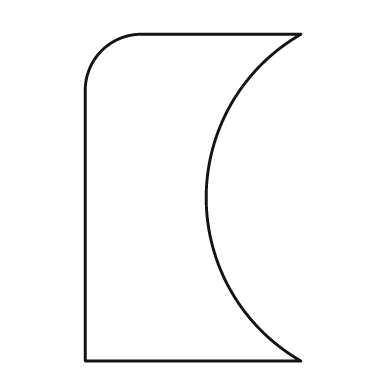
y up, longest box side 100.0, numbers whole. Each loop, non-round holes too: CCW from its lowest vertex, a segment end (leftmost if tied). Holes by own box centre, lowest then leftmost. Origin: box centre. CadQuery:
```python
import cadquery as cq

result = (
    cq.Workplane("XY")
    .moveTo(-33.0, -50.0)
    .lineTo(33.0, -50.0)
    .threePointArc((4.0, 0.0), (33.0, 50.0))
    .lineTo(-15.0, 50.0)
    .threePointArc((-28.0, 45.0), (-33.0, 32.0))
    .close()
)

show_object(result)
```